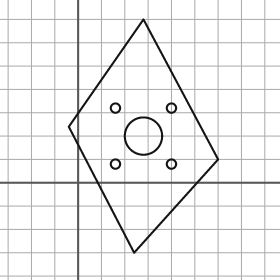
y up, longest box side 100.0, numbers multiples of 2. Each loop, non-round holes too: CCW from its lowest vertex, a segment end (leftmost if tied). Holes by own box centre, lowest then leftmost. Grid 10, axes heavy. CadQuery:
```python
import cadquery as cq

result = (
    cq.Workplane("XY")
    .moveTo(24.0, -30.0)
    .lineTo(60.0, 10.0)
    .lineTo(28.0, 70.0)
    .lineTo(-4.0, 24.0)
    .close()
    .moveTo(16.0, 8.0)
    .circle(2.0)
    .moveTo(40.0, 8.0)
    .circle(2.0)
    .moveTo(28.0, 20.0)
    .circle(8.0)
    .moveTo(16.0, 32.0)
    .circle(2.0)
    .moveTo(40.0, 32.0)
    .circle(2.0)
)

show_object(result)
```